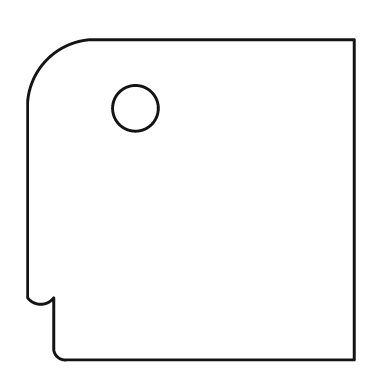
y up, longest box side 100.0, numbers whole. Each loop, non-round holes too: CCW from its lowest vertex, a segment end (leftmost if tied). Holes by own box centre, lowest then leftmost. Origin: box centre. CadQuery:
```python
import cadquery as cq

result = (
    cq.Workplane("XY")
    .moveTo(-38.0, -49.0)
    .lineTo(50.0, -49.0)
    .lineTo(50.0, 49.0)
    .lineTo(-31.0, 49.0)
    .threePointArc((-44.0, 43.0), (-50.0, 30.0))
    .lineTo(-50.0, -30.0)
    .threePointArc((-46.0, -32.0), (-42.0, -30.0))
    .lineTo(-42.0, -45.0)
    .threePointArc((-41.0, -48.0), (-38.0, -49.0))
    .close()
    .moveTo(-17.0, 28.0)
    .circle(7.0)
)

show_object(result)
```